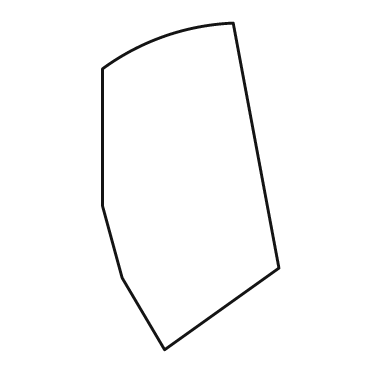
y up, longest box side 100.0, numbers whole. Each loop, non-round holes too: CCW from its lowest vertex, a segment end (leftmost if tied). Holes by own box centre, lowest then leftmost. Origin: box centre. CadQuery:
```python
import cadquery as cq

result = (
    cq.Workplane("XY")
    .moveTo(-8.0, -50.0)
    .lineTo(27.0, -25.0)
    .lineTo(13.0, 50.0)
    .threePointArc((-8.0, 46.0), (-27.0, 36.0))
    .lineTo(-27.0, -6.0)
    .lineTo(-21.0, -28.0)
    .close()
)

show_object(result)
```